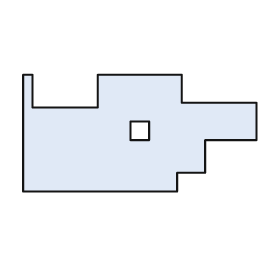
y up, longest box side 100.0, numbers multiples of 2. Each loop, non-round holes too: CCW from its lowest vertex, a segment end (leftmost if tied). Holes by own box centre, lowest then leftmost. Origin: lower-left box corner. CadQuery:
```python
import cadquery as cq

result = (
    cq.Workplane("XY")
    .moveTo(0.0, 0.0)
    .lineTo(66.0, 0.0)
    .lineTo(66.0, 8.0)
    .lineTo(78.0, 8.0)
    .lineTo(78.0, 22.0)
    .lineTo(100.0, 22.0)
    .lineTo(100.0, 38.0)
    .lineTo(68.0, 38.0)
    .lineTo(68.0, 50.0)
    .lineTo(32.0, 50.0)
    .lineTo(32.0, 36.0)
    .lineTo(4.0, 36.0)
    .lineTo(4.0, 50.0)
    .lineTo(0.0, 50.0)
    .close()
    .moveTo(46.0, 22.0)
    .lineTo(54.0, 22.0)
    .lineTo(54.0, 30.0)
    .lineTo(46.0, 30.0)
    .close()
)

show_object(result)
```